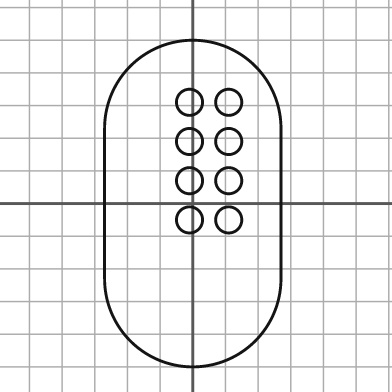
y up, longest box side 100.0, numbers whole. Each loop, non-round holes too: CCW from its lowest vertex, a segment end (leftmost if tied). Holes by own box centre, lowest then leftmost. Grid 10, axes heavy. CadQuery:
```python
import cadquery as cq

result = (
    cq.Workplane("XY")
    .moveTo(-27.0, -23.0)
    .threePointArc((0.0, -50.0), (27.0, -23.0))
    .lineTo(27.0, 23.0)
    .threePointArc((0.0, 50.0), (-27.0, 23.0))
    .close()
    .moveTo(-1.0, -5.0)
    .circle(4.0)
    .moveTo(11.0, -5.0)
    .circle(4.0)
    .moveTo(-1.0, 7.0)
    .circle(4.0)
    .moveTo(11.0, 7.0)
    .circle(4.0)
    .moveTo(-1.0, 19.0)
    .circle(4.0)
    .moveTo(11.0, 19.0)
    .circle(4.0)
    .moveTo(-1.0, 31.0)
    .circle(4.0)
    .moveTo(11.0, 31.0)
    .circle(4.0)
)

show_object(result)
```